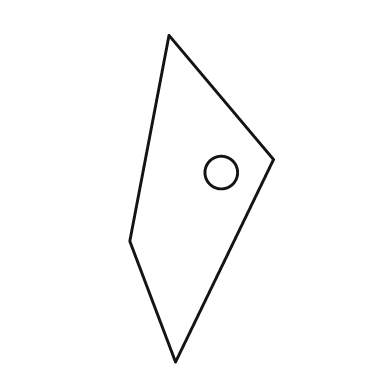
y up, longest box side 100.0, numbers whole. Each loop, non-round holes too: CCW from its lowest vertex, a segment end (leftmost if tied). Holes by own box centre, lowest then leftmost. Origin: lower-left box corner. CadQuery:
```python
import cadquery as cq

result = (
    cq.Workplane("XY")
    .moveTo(14.0, 0.0)
    .lineTo(44.0, 62.0)
    .lineTo(12.0, 100.0)
    .lineTo(0.0, 37.0)
    .close()
    .moveTo(28.0, 58.0)
    .circle(5.0)
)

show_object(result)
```